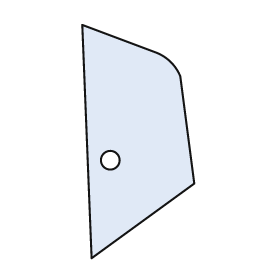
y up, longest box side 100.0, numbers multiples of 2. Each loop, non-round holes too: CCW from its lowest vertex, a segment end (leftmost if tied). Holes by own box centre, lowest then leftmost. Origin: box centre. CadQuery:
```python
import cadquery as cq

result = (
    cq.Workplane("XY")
    .moveTo(-20.0, -50.0)
    .lineTo(24.0, -18.0)
    .lineTo(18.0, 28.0)
    .threePointArc((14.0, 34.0), (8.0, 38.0))
    .lineTo(-24.0, 50.0)
    .close()
    .moveTo(-12.0, -8.0)
    .circle(4.0)
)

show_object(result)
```